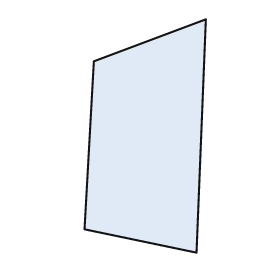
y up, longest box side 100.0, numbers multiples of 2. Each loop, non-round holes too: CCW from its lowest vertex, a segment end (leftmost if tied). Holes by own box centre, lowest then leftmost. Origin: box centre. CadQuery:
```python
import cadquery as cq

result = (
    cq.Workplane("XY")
    .moveTo(22.0, -50.0)
    .lineTo(26.0, 50.0)
    .lineTo(-22.0, 32.0)
    .lineTo(-26.0, -40.0)
    .close()
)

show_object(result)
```